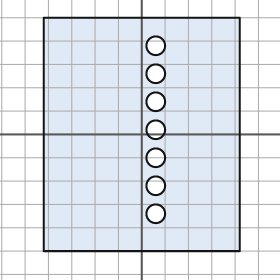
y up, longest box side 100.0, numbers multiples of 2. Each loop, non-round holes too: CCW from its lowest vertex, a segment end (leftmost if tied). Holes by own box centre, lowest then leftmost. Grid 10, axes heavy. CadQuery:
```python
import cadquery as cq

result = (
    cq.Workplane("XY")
    .moveTo(-42.0, -50.0)
    .lineTo(42.0, -50.0)
    .lineTo(42.0, 50.0)
    .lineTo(-42.0, 50.0)
    .close()
    .moveTo(6.0, -34.0)
    .circle(4.0)
    .moveTo(6.0, -22.0)
    .circle(4.0)
    .moveTo(6.0, -10.0)
    .circle(4.0)
    .moveTo(6.0, 2.0)
    .circle(4.0)
    .moveTo(6.0, 14.0)
    .circle(4.0)
    .moveTo(6.0, 26.0)
    .circle(4.0)
    .moveTo(6.0, 38.0)
    .circle(4.0)
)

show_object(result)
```